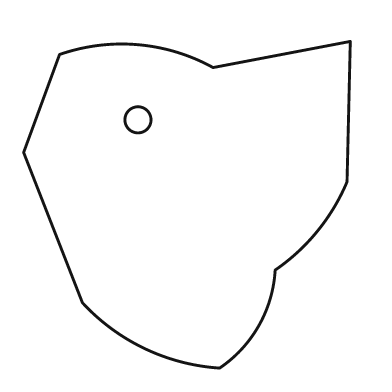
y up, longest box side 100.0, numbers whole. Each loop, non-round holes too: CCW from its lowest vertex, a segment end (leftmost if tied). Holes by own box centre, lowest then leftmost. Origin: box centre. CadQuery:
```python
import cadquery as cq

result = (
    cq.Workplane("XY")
    .moveTo(10.0, -50.0)
    .threePointArc((22.0, -37.0), (27.0, -20.0))
    .threePointArc((40.0, -8.0), (49.0, 7.0))
    .lineTo(50.0, 50.0)
    .lineTo(8.0, 42.0)
    .threePointArc((-15.0, 49.0), (-39.0, 46.0))
    .lineTo(-50.0, 16.0)
    .lineTo(-32.0, -30.0)
    .threePointArc((-13.0, -44.0), (10.0, -50.0))
    .close()
    .moveTo(-15.0, 26.0)
    .circle(4.0)
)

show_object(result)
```